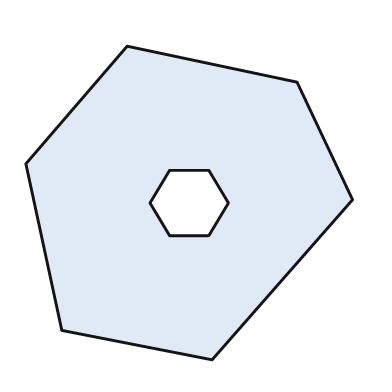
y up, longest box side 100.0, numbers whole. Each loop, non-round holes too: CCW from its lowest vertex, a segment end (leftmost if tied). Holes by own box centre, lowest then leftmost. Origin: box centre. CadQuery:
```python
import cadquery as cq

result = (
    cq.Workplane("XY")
    .moveTo(7.0, -48.0)
    .lineTo(50.0, 1.0)
    .lineTo(33.0, 37.0)
    .lineTo(-19.0, 48.0)
    .lineTo(-50.0, 12.0)
    .lineTo(-39.0, -39.0)
    .close()
    .moveTo(-6.0, -10.0)
    .lineTo(6.0, -10.0)
    .lineTo(12.0, 0.0)
    .lineTo(6.0, 10.0)
    .lineTo(-6.0, 10.0)
    .lineTo(-12.0, 0.0)
    .close()
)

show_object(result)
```